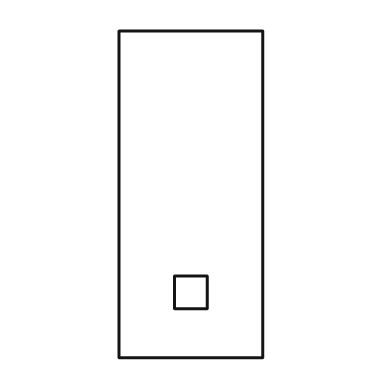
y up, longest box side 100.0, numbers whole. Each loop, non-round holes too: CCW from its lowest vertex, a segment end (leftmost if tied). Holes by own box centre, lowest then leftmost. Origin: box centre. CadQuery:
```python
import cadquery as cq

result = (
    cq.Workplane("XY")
    .moveTo(-22.0, -50.0)
    .lineTo(22.0, -50.0)
    .lineTo(22.0, 50.0)
    .lineTo(-22.0, 50.0)
    .close()
    .moveTo(-5.0, -35.0)
    .lineTo(5.0, -35.0)
    .lineTo(5.0, -25.0)
    .lineTo(-5.0, -25.0)
    .close()
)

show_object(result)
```